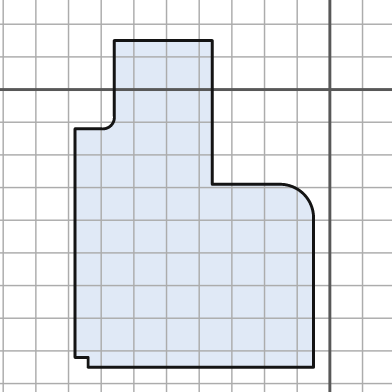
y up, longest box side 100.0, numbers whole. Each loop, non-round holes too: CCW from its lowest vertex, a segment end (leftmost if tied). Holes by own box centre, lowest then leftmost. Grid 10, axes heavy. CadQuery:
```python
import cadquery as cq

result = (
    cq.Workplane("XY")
    .moveTo(-74.0, -85.0)
    .lineTo(-5.0, -85.0)
    .lineTo(-5.0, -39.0)
    .threePointArc((-8.0, -32.0), (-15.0, -29.0))
    .lineTo(-36.0, -29.0)
    .lineTo(-36.0, 15.0)
    .lineTo(-66.0, 15.0)
    .lineTo(-66.0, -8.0)
    .threePointArc((-67.0, -11.0), (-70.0, -12.0))
    .lineTo(-78.0, -12.0)
    .lineTo(-78.0, -82.0)
    .lineTo(-74.0, -82.0)
    .close()
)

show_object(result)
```